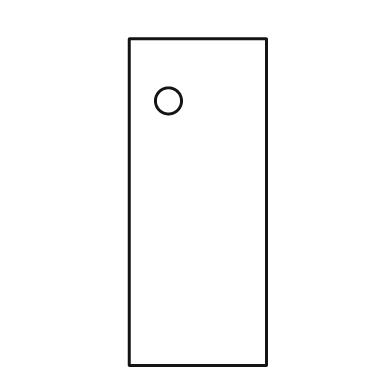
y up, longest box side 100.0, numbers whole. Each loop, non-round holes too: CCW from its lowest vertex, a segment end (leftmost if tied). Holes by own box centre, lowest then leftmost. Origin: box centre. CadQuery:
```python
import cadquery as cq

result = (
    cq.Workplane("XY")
    .moveTo(-21.0, -50.0)
    .lineTo(21.0, -50.0)
    .lineTo(21.0, 50.0)
    .lineTo(-21.0, 50.0)
    .close()
    .moveTo(-9.0, 31.0)
    .circle(4.0)
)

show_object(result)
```